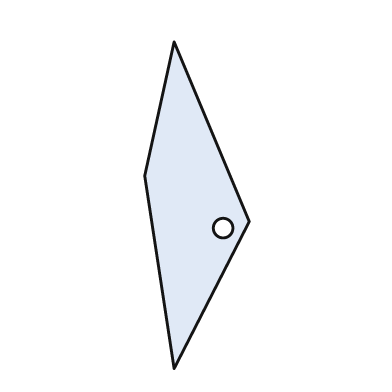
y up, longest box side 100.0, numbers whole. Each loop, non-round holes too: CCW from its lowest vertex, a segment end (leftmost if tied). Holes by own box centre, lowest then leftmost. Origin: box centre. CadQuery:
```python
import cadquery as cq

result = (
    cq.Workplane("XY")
    .moveTo(-7.0, -50.0)
    .lineTo(16.0, -5.0)
    .lineTo(-7.0, 50.0)
    .lineTo(-16.0, 9.0)
    .close()
    .moveTo(8.0, -7.0)
    .circle(3.0)
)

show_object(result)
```